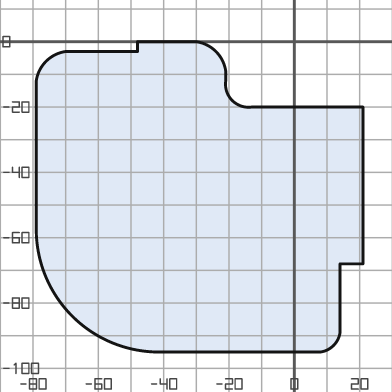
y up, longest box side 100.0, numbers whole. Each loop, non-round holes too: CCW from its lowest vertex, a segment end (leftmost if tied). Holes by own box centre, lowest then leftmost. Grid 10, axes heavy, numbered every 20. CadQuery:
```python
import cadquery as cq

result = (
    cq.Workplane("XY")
    .moveTo(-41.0, -95.0)
    .lineTo(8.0, -95.0)
    .threePointArc((12.0, -93.0), (14.0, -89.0))
    .lineTo(14.0, -68.0)
    .lineTo(21.0, -68.0)
    .lineTo(21.0, -20.0)
    .lineTo(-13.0, -20.0)
    .threePointArc((-19.0, -18.0), (-21.0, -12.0))
    .lineTo(-21.0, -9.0)
    .threePointArc((-24.0, -3.0), (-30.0, 0.0))
    .lineTo(-48.0, 0.0)
    .lineTo(-48.0, -3.0)
    .lineTo(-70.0, -3.0)
    .threePointArc((-76.0, -6.0), (-79.0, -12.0))
    .lineTo(-79.0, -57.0)
    .threePointArc((-68.0, -84.0), (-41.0, -95.0))
    .close()
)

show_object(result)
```